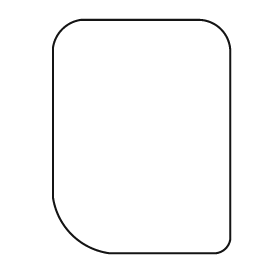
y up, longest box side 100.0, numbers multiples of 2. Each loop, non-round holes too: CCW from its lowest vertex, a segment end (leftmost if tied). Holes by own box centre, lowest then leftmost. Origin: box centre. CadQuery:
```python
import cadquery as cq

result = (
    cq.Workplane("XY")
    .moveTo(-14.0, -50.0)
    .lineTo(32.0, -50.0)
    .threePointArc((36.0, -48.0), (38.0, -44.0))
    .lineTo(38.0, 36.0)
    .threePointArc((34.0, 46.0), (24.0, 50.0))
    .lineTo(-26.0, 50.0)
    .threePointArc((-34.0, 46.0), (-38.0, 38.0))
    .lineTo(-38.0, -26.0)
    .threePointArc((-30.0, -42.0), (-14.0, -50.0))
    .close()
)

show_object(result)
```